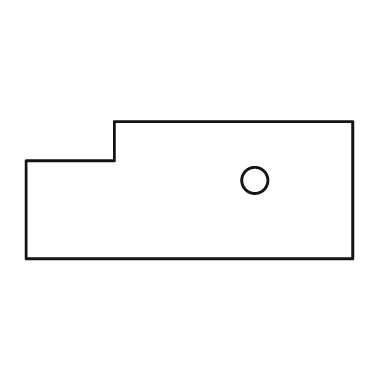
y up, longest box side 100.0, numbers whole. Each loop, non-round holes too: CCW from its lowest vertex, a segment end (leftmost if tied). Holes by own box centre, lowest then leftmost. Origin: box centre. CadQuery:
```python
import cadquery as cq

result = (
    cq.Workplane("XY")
    .moveTo(-50.0, -21.0)
    .lineTo(50.0, -21.0)
    .lineTo(50.0, 21.0)
    .lineTo(-23.0, 21.0)
    .lineTo(-23.0, 9.0)
    .lineTo(-50.0, 9.0)
    .close()
    .moveTo(20.0, 3.0)
    .circle(4.0)
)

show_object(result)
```